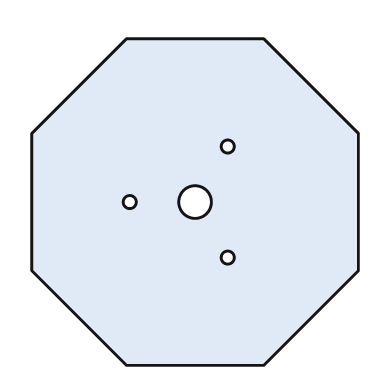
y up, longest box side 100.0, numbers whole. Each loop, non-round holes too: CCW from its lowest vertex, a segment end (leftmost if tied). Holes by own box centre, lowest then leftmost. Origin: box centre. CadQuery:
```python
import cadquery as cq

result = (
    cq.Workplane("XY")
    .moveTo(-21.0, -50.0)
    .lineTo(21.0, -50.0)
    .lineTo(50.0, -21.0)
    .lineTo(50.0, 21.0)
    .lineTo(21.0, 50.0)
    .lineTo(-21.0, 50.0)
    .lineTo(-50.0, 21.0)
    .lineTo(-50.0, -21.0)
    .close()
    .moveTo(10.0, -17.0)
    .circle(2.0)
    .moveTo(-20.0, 0.0)
    .circle(2.0)
    .moveTo(0.0, 0.0)
    .circle(5.0)
    .moveTo(10.0, 17.0)
    .circle(2.0)
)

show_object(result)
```